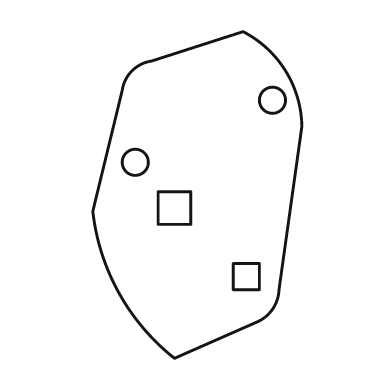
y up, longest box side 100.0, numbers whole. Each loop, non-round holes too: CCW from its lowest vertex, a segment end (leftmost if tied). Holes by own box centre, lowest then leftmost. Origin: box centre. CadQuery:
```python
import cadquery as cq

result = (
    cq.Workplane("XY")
    .moveTo(-7.0, -50.0)
    .lineTo(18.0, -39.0)
    .threePointArc((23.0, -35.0), (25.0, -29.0))
    .lineTo(32.0, 21.0)
    .threePointArc((27.0, 38.0), (14.0, 50.0))
    .lineTo(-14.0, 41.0)
    .threePointArc((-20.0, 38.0), (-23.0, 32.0))
    .lineTo(-32.0, -5.0)
    .threePointArc((-24.0, -30.0), (-7.0, -50.0))
    .close()
    .moveTo(11.0, -29.0)
    .lineTo(19.0, -29.0)
    .lineTo(19.0, -21.0)
    .lineTo(11.0, -21.0)
    .close()
    .moveTo(-12.0, -9.0)
    .lineTo(-2.0, -9.0)
    .lineTo(-2.0, 1.0)
    .lineTo(-12.0, 1.0)
    .close()
    .moveTo(-19.0, 10.0)
    .circle(4.0)
    .moveTo(23.0, 29.0)
    .circle(4.0)
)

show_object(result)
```